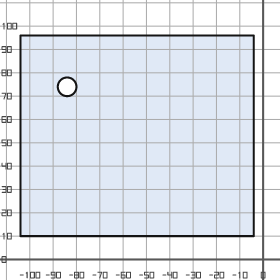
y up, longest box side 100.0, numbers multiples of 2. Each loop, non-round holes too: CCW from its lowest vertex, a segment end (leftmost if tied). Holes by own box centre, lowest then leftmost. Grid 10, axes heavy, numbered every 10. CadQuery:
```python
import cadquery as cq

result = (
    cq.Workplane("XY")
    .moveTo(-104.0, 10.0)
    .lineTo(-4.0, 10.0)
    .lineTo(-4.0, 96.0)
    .lineTo(-104.0, 96.0)
    .close()
    .moveTo(-84.0, 74.0)
    .circle(4.0)
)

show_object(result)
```